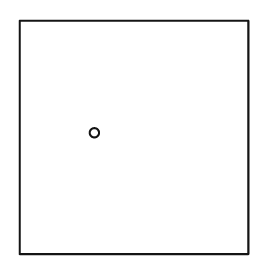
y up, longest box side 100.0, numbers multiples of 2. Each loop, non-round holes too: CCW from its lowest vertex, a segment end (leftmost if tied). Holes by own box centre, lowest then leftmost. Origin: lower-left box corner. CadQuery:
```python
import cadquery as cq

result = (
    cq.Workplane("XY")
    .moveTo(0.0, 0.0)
    .lineTo(98.0, 0.0)
    .lineTo(98.0, 100.0)
    .lineTo(0.0, 100.0)
    .close()
    .moveTo(32.0, 52.0)
    .circle(2.0)
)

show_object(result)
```